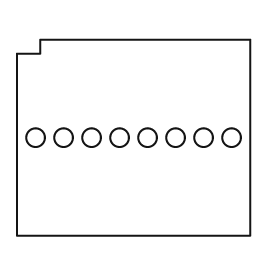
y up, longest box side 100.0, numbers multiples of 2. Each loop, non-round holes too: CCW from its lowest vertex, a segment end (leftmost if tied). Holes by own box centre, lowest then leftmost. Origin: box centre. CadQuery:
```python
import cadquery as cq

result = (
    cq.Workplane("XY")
    .moveTo(-50.0, -42.0)
    .lineTo(50.0, -42.0)
    .lineTo(50.0, 42.0)
    .lineTo(-40.0, 42.0)
    .lineTo(-40.0, 36.0)
    .lineTo(-50.0, 36.0)
    .close()
    .moveTo(-42.0, 0.0)
    .circle(4.0)
    .moveTo(-30.0, 0.0)
    .circle(4.0)
    .moveTo(-18.0, 0.0)
    .circle(4.0)
    .moveTo(-6.0, 0.0)
    .circle(4.0)
    .moveTo(6.0, 0.0)
    .circle(4.0)
    .moveTo(18.0, 0.0)
    .circle(4.0)
    .moveTo(30.0, 0.0)
    .circle(4.0)
    .moveTo(42.0, 0.0)
    .circle(4.0)
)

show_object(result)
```